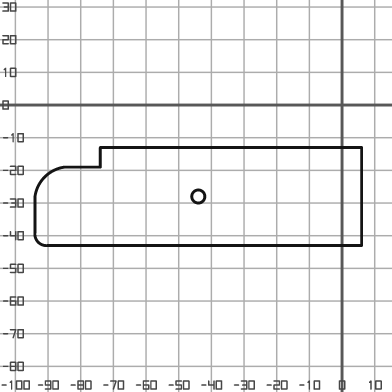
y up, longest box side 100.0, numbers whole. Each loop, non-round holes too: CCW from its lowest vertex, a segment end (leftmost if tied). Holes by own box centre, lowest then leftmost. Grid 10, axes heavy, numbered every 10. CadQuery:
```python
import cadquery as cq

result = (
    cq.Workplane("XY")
    .moveTo(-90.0, -43.0)
    .lineTo(6.0, -43.0)
    .lineTo(6.0, -13.0)
    .lineTo(-74.0, -13.0)
    .lineTo(-74.0, -19.0)
    .lineTo(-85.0, -19.0)
    .threePointArc((-91.0, -22.0), (-94.0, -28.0))
    .lineTo(-94.0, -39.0)
    .threePointArc((-93.0, -42.0), (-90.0, -43.0))
    .close()
    .moveTo(-44.0, -28.0)
    .circle(2.0)
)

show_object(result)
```